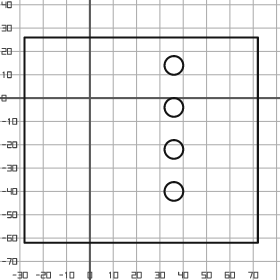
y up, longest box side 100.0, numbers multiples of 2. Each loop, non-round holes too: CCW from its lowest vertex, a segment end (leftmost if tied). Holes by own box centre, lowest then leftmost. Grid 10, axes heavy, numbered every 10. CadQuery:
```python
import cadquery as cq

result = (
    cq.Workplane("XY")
    .moveTo(-28.0, -62.0)
    .lineTo(72.0, -62.0)
    .lineTo(72.0, 26.0)
    .lineTo(-28.0, 26.0)
    .close()
    .moveTo(36.0, -40.0)
    .circle(4.0)
    .moveTo(36.0, -22.0)
    .circle(4.0)
    .moveTo(36.0, -4.0)
    .circle(4.0)
    .moveTo(36.0, 14.0)
    .circle(4.0)
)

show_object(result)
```